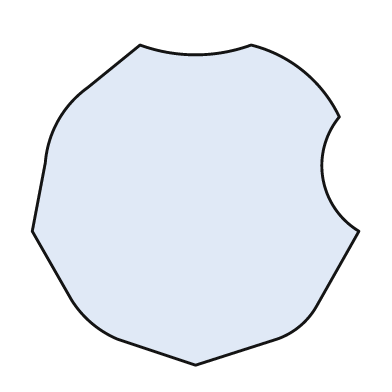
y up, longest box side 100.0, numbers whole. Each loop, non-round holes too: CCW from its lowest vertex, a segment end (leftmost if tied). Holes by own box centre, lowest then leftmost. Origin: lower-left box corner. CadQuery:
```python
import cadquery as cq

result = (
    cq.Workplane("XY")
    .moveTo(50.0, 0.0)
    .lineTo(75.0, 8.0)
    .threePointArc((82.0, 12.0), (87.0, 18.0))
    .lineTo(100.0, 41.0)
    .threePointArc((89.0, 57.0), (94.0, 76.0))
    .threePointArc((83.0, 90.0), (67.0, 98.0))
    .threePointArc((50.0, 95.0), (33.0, 98.0))
    .lineTo(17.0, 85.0)
    .threePointArc((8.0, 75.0), (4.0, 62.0))
    .lineTo(0.0, 41.0)
    .lineTo(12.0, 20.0)
    .threePointArc((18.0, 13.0), (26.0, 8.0))
    .close()
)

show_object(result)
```